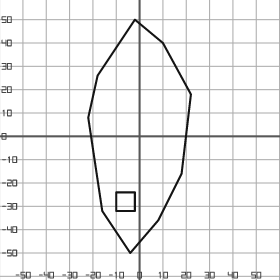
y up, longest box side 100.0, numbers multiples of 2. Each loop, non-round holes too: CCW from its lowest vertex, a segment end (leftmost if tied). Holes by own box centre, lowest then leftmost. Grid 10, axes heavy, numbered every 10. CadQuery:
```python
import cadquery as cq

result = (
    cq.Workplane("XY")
    .moveTo(-4.0, -50.0)
    .lineTo(8.0, -36.0)
    .lineTo(18.0, -16.0)
    .lineTo(22.0, 18.0)
    .lineTo(10.0, 40.0)
    .lineTo(-2.0, 50.0)
    .lineTo(-18.0, 26.0)
    .lineTo(-22.0, 8.0)
    .lineTo(-16.0, -32.0)
    .close()
    .moveTo(-10.0, -32.0)
    .lineTo(-2.0, -32.0)
    .lineTo(-2.0, -24.0)
    .lineTo(-10.0, -24.0)
    .close()
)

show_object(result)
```